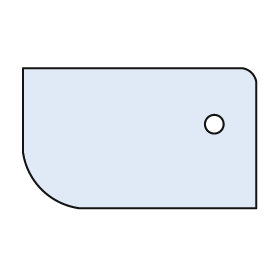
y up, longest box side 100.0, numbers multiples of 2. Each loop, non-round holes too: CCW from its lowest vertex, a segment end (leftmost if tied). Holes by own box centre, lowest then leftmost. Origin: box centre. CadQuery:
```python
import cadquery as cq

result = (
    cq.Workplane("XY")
    .moveTo(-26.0, -30.0)
    .lineTo(50.0, -30.0)
    .lineTo(50.0, 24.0)
    .threePointArc((48.0, 28.0), (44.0, 30.0))
    .lineTo(-50.0, 30.0)
    .lineTo(-50.0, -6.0)
    .threePointArc((-42.0, -22.0), (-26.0, -30.0))
    .close()
    .moveTo(32.0, 6.0)
    .circle(4.0)
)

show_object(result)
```